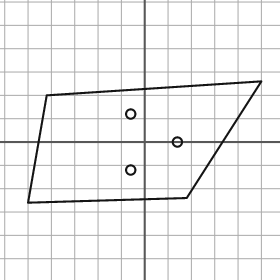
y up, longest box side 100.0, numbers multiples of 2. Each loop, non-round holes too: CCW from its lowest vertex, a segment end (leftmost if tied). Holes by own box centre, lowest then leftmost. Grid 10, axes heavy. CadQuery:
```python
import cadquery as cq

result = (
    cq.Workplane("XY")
    .moveTo(-50.0, -26.0)
    .lineTo(18.0, -24.0)
    .lineTo(50.0, 26.0)
    .lineTo(-42.0, 20.0)
    .close()
    .moveTo(-6.0, -12.0)
    .circle(2.0)
    .moveTo(14.0, 0.0)
    .circle(2.0)
    .moveTo(-6.0, 12.0)
    .circle(2.0)
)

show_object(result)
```